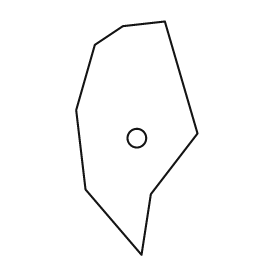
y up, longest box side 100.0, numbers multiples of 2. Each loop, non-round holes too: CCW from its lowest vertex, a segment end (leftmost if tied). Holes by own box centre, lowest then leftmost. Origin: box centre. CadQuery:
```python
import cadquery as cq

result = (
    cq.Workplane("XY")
    .moveTo(2.0, -50.0)
    .lineTo(6.0, -24.0)
    .lineTo(26.0, 2.0)
    .lineTo(12.0, 50.0)
    .lineTo(-6.0, 48.0)
    .lineTo(-18.0, 40.0)
    .lineTo(-26.0, 12.0)
    .lineTo(-22.0, -22.0)
    .close()
    .moveTo(0.0, 0.0)
    .circle(4.0)
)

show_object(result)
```